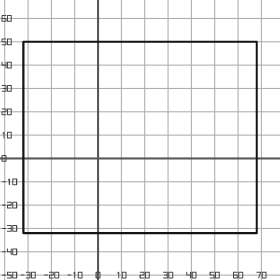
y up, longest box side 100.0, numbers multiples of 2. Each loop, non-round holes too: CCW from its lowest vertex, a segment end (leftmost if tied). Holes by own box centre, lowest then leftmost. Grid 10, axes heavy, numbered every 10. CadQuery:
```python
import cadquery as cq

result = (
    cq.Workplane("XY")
    .moveTo(-32.0, -32.0)
    .lineTo(68.0, -32.0)
    .lineTo(68.0, 50.0)
    .lineTo(-32.0, 50.0)
    .close()
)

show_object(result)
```